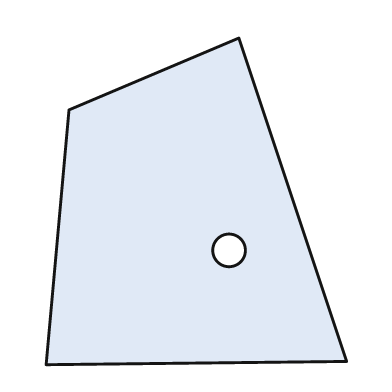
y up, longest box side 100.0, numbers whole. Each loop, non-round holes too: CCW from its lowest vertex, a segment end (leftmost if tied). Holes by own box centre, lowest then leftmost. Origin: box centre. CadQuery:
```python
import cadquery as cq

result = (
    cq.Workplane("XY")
    .moveTo(-46.0, -50.0)
    .lineTo(46.0, -49.0)
    .lineTo(13.0, 50.0)
    .lineTo(-39.0, 28.0)
    .close()
    .moveTo(10.0, -15.0)
    .circle(5.0)
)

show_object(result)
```